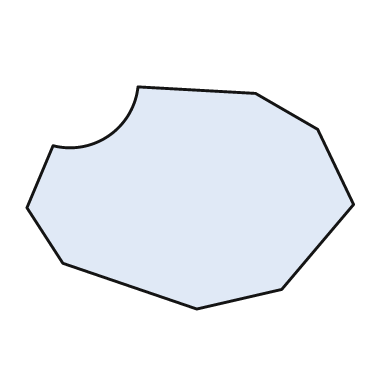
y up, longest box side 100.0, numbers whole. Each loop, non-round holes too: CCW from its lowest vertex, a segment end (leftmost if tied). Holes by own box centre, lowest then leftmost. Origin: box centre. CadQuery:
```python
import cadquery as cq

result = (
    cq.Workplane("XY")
    .moveTo(2.0, -34.0)
    .lineTo(28.0, -28.0)
    .lineTo(50.0, -2.0)
    .lineTo(39.0, 21.0)
    .lineTo(20.0, 32.0)
    .lineTo(-16.0, 34.0)
    .threePointArc((-25.0, 19.0), (-42.0, 16.0))
    .lineTo(-50.0, -3.0)
    .lineTo(-39.0, -20.0)
    .close()
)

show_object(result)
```